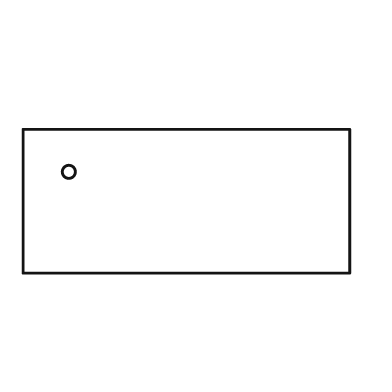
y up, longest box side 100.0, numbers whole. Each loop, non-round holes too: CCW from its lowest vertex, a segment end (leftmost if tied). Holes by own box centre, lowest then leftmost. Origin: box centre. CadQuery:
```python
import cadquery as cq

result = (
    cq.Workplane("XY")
    .moveTo(-50.0, -22.0)
    .lineTo(50.0, -22.0)
    .lineTo(50.0, 22.0)
    .lineTo(-50.0, 22.0)
    .close()
    .moveTo(-36.0, 9.0)
    .circle(2.0)
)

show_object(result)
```